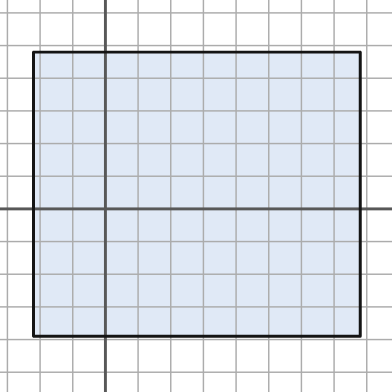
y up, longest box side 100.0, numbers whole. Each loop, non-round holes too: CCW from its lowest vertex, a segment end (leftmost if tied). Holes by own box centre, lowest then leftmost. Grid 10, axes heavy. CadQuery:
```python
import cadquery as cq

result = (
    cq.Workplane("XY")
    .moveTo(-22.0, -39.0)
    .lineTo(78.0, -39.0)
    .lineTo(78.0, 48.0)
    .lineTo(-22.0, 48.0)
    .close()
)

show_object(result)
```